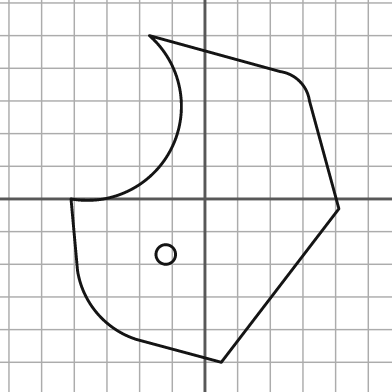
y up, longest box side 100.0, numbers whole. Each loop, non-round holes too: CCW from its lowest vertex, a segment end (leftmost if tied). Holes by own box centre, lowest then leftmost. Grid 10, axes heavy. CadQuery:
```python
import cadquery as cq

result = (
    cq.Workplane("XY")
    .moveTo(5.0, -50.0)
    .lineTo(41.0, -3.0)
    .lineTo(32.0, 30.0)
    .threePointArc((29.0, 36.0), (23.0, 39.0))
    .lineTo(-17.0, 50.0)
    .threePointArc((-10.0, 16.0), (-41.0, 0.0))
    .lineTo(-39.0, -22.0)
    .threePointArc((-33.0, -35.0), (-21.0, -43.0))
    .close()
    .moveTo(-12.0, -17.0)
    .circle(3.0)
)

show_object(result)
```